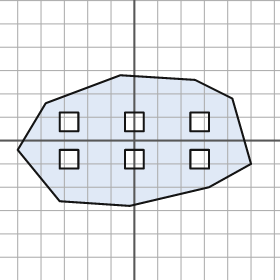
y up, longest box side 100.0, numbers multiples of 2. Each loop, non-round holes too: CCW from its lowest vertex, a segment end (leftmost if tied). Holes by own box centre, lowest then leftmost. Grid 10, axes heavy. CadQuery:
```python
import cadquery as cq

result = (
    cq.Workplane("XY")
    .moveTo(-2.0, -28.0)
    .lineTo(32.0, -20.0)
    .lineTo(50.0, -10.0)
    .lineTo(42.0, 18.0)
    .lineTo(26.0, 26.0)
    .lineTo(-6.0, 28.0)
    .lineTo(-38.0, 16.0)
    .lineTo(-50.0, -4.0)
    .lineTo(-32.0, -26.0)
    .close()
    .moveTo(-32.0, -12.0)
    .lineTo(-24.0, -12.0)
    .lineTo(-24.0, -4.0)
    .lineTo(-32.0, -4.0)
    .close()
    .moveTo(-4.0, -12.0)
    .lineTo(4.0, -12.0)
    .lineTo(4.0, -4.0)
    .lineTo(-4.0, -4.0)
    .close()
    .moveTo(24.0, -12.0)
    .lineTo(32.0, -12.0)
    .lineTo(32.0, -4.0)
    .lineTo(24.0, -4.0)
    .close()
    .moveTo(-32.0, 4.0)
    .lineTo(-24.0, 4.0)
    .lineTo(-24.0, 12.0)
    .lineTo(-32.0, 12.0)
    .close()
    .moveTo(-4.0, 4.0)
    .lineTo(4.0, 4.0)
    .lineTo(4.0, 12.0)
    .lineTo(-4.0, 12.0)
    .close()
    .moveTo(24.0, 4.0)
    .lineTo(32.0, 4.0)
    .lineTo(32.0, 12.0)
    .lineTo(24.0, 12.0)
    .close()
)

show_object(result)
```